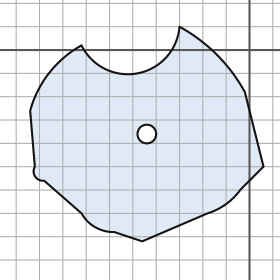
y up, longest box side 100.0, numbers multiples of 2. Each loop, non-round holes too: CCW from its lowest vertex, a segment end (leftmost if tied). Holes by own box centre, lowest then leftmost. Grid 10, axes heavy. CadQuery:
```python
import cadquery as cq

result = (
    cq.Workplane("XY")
    .moveTo(-46.0, -82.0)
    .lineTo(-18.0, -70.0)
    .threePointArc((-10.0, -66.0), (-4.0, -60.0))
    .lineTo(6.0, -50.0)
    .lineTo(-2.0, -18.0)
    .threePointArc((-14.0, -2.0), (-30.0, 10.0))
    .threePointArc((-48.0, -10.0), (-72.0, 2.0))
    .threePointArc((-86.0, -10.0), (-94.0, -26.0))
    .lineTo(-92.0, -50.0)
    .threePointArc((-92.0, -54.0), (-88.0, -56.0))
    .lineTo(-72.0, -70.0)
    .threePointArc((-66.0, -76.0), (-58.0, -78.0))
    .close()
    .moveTo(-44.0, -36.0)
    .circle(4.0)
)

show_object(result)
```